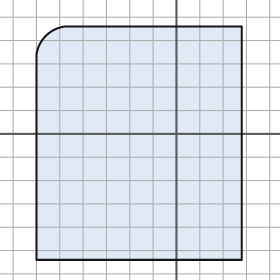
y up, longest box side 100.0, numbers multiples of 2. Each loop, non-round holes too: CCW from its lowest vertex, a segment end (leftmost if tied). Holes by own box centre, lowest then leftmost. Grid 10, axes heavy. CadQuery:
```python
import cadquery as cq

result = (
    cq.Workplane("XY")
    .moveTo(-60.0, -54.0)
    .lineTo(28.0, -54.0)
    .lineTo(28.0, 46.0)
    .lineTo(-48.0, 46.0)
    .threePointArc((-56.0, 42.0), (-60.0, 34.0))
    .close()
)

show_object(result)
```